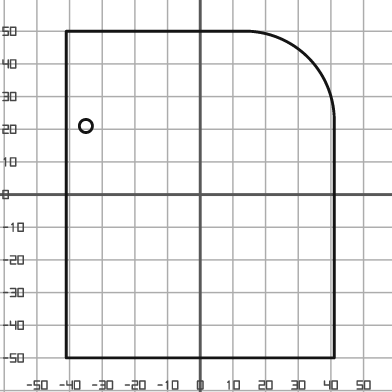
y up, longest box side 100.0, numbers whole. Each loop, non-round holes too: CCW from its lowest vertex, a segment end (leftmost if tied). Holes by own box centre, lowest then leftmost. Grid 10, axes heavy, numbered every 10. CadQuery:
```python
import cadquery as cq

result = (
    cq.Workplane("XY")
    .moveTo(-41.0, -50.0)
    .lineTo(41.0, -50.0)
    .lineTo(41.0, 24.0)
    .threePointArc((33.0, 42.0), (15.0, 50.0))
    .lineTo(-41.0, 50.0)
    .close()
    .moveTo(-35.0, 21.0)
    .circle(2.0)
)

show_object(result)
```